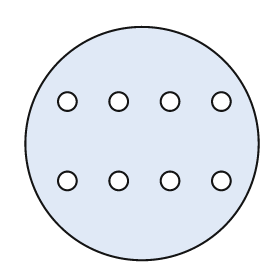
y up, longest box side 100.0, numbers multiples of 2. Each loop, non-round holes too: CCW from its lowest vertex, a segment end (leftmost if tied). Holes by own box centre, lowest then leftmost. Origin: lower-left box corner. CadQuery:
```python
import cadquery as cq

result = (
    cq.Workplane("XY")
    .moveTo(50.0, 50.0)
    .circle(50.0)
    .moveTo(18.0, 34.0)
    .circle(4.0)
    .moveTo(40.0, 34.0)
    .circle(4.0)
    .moveTo(62.0, 34.0)
    .circle(4.0)
    .moveTo(84.0, 34.0)
    .circle(4.0)
    .moveTo(18.0, 68.0)
    .circle(4.0)
    .moveTo(40.0, 68.0)
    .circle(4.0)
    .moveTo(62.0, 68.0)
    .circle(4.0)
    .moveTo(84.0, 68.0)
    .circle(4.0)
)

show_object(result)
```